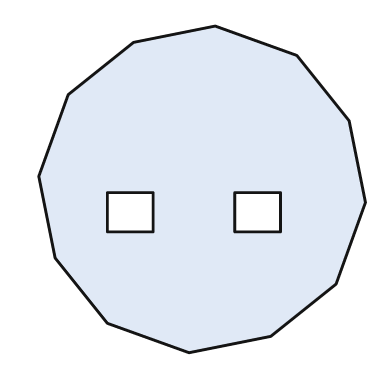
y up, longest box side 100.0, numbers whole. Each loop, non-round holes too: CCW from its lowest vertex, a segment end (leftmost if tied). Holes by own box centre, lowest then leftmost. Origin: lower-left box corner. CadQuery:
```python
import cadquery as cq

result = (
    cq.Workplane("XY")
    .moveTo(46.0, 0.0)
    .lineTo(71.0, 5.0)
    .lineTo(91.0, 21.0)
    .lineTo(100.0, 46.0)
    .lineTo(95.0, 71.0)
    .lineTo(79.0, 91.0)
    .lineTo(54.0, 100.0)
    .lineTo(29.0, 95.0)
    .lineTo(9.0, 79.0)
    .lineTo(0.0, 54.0)
    .lineTo(5.0, 29.0)
    .lineTo(21.0, 9.0)
    .close()
    .moveTo(21.0, 37.0)
    .lineTo(35.0, 37.0)
    .lineTo(35.0, 49.0)
    .lineTo(21.0, 49.0)
    .close()
    .moveTo(60.0, 37.0)
    .lineTo(74.0, 37.0)
    .lineTo(74.0, 49.0)
    .lineTo(60.0, 49.0)
    .close()
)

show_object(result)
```